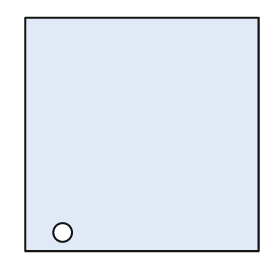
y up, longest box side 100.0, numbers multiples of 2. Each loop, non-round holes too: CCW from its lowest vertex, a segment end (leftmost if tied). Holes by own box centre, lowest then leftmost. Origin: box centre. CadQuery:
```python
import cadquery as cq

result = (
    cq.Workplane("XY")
    .moveTo(-50.0, -50.0)
    .lineTo(50.0, -50.0)
    .lineTo(50.0, 50.0)
    .lineTo(-50.0, 50.0)
    .close()
    .moveTo(-34.0, -42.0)
    .circle(4.0)
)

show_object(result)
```